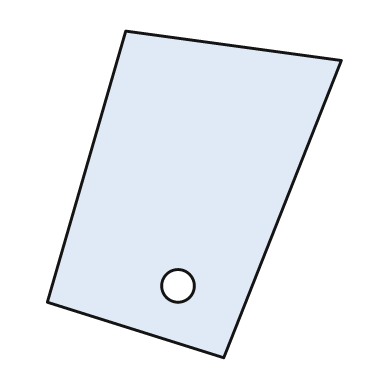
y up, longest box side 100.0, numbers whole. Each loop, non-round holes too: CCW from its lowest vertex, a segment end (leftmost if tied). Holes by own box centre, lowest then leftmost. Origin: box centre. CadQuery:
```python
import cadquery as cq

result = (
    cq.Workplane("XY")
    .moveTo(9.0, -50.0)
    .lineTo(45.0, 41.0)
    .lineTo(-21.0, 50.0)
    .lineTo(-45.0, -33.0)
    .close()
    .moveTo(-5.0, -28.0)
    .circle(5.0)
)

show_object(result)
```